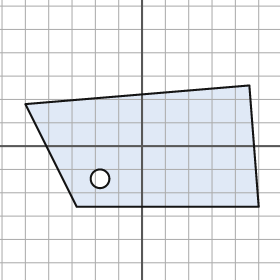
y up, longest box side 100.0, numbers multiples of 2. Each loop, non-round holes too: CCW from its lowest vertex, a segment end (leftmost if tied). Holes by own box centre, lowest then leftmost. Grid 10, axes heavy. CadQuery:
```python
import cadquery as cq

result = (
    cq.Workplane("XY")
    .moveTo(-28.0, -26.0)
    .lineTo(50.0, -26.0)
    .lineTo(46.0, 26.0)
    .lineTo(-50.0, 18.0)
    .close()
    .moveTo(-18.0, -14.0)
    .circle(4.0)
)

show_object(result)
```